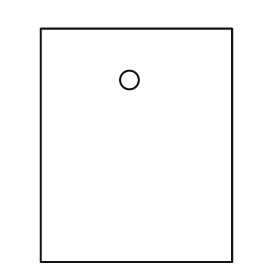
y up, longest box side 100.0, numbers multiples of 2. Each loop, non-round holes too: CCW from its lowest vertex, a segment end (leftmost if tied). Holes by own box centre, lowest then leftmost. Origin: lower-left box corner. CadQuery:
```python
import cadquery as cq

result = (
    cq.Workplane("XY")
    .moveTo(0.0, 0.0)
    .lineTo(82.0, 0.0)
    .lineTo(82.0, 100.0)
    .lineTo(0.0, 100.0)
    .close()
    .moveTo(38.0, 78.0)
    .circle(4.0)
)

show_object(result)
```